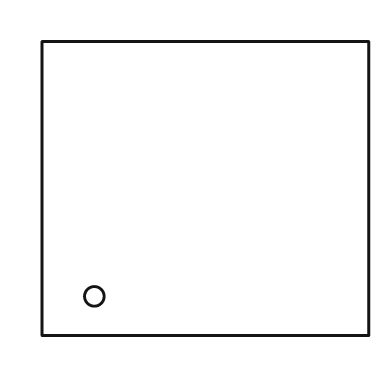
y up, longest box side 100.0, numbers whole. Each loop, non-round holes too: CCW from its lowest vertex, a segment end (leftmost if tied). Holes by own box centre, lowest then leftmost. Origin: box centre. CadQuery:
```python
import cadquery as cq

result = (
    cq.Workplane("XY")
    .moveTo(-50.0, -45.0)
    .lineTo(50.0, -45.0)
    .lineTo(50.0, 45.0)
    .lineTo(-50.0, 45.0)
    .close()
    .moveTo(-34.0, -33.0)
    .circle(3.0)
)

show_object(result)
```